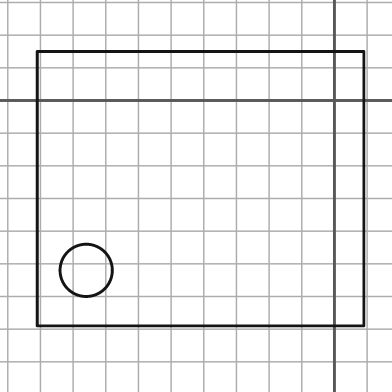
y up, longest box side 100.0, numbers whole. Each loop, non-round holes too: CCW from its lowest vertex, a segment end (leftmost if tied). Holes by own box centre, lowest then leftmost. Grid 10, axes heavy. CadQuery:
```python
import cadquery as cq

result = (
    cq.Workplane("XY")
    .moveTo(-91.0, -69.0)
    .lineTo(9.0, -69.0)
    .lineTo(9.0, 15.0)
    .lineTo(-91.0, 15.0)
    .close()
    .moveTo(-76.0, -52.0)
    .circle(8.0)
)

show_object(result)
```